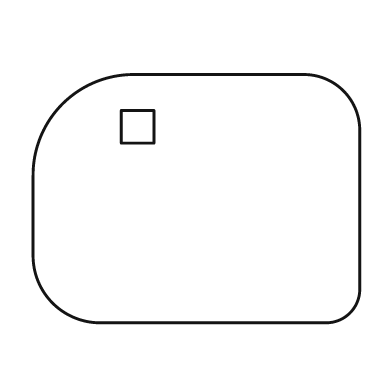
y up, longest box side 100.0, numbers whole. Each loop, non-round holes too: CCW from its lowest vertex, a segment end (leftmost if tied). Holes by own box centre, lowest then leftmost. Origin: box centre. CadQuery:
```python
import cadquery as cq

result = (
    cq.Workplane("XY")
    .moveTo(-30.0, -38.0)
    .lineTo(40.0, -38.0)
    .threePointArc((47.0, -35.0), (50.0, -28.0))
    .lineTo(50.0, 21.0)
    .threePointArc((45.0, 33.0), (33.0, 38.0))
    .lineTo(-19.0, 38.0)
    .threePointArc((-41.0, 29.0), (-50.0, 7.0))
    .lineTo(-50.0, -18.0)
    .threePointArc((-44.0, -32.0), (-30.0, -38.0))
    .close()
    .moveTo(-23.0, 17.0)
    .lineTo(-13.0, 17.0)
    .lineTo(-13.0, 27.0)
    .lineTo(-23.0, 27.0)
    .close()
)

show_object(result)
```